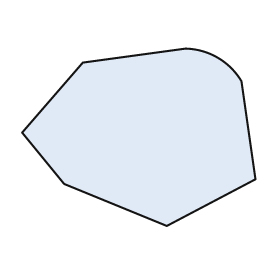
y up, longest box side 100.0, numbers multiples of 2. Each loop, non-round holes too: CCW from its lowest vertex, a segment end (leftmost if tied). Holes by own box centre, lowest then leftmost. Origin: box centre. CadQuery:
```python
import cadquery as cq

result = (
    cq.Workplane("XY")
    .moveTo(12.0, -38.0)
    .lineTo(50.0, -18.0)
    .lineTo(44.0, 24.0)
    .threePointArc((34.0, 34.0), (20.0, 38.0))
    .lineTo(-24.0, 32.0)
    .lineTo(-50.0, 2.0)
    .lineTo(-32.0, -20.0)
    .close()
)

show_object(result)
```